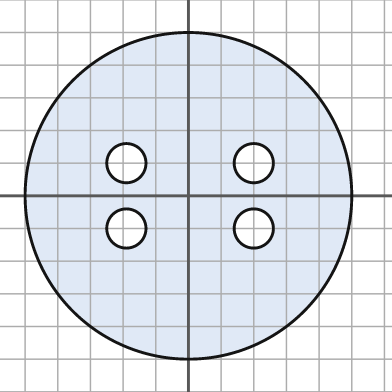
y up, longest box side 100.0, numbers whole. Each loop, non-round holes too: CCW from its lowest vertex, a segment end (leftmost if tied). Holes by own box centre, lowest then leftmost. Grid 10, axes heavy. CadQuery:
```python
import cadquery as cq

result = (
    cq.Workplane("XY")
    .moveTo(0.0, 0.0)
    .circle(50.0)
    .moveTo(-19.0, -10.0)
    .circle(6.0)
    .moveTo(20.0, -10.0)
    .circle(6.0)
    .moveTo(-19.0, 10.0)
    .circle(6.0)
    .moveTo(20.0, 10.0)
    .circle(6.0)
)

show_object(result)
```